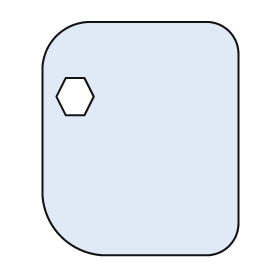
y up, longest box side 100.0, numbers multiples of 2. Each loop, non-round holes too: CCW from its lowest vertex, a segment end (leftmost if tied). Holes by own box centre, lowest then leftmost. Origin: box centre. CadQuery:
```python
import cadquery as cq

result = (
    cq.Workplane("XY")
    .moveTo(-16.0, -50.0)
    .lineTo(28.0, -50.0)
    .threePointArc((38.0, -46.0), (42.0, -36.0))
    .lineTo(42.0, 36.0)
    .threePointArc((38.0, 46.0), (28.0, 50.0))
    .lineTo(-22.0, 50.0)
    .threePointArc((-36.0, 44.0), (-42.0, 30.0))
    .lineTo(-42.0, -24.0)
    .threePointArc((-34.0, -42.0), (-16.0, -50.0))
    .close()
    .moveTo(-32.0, 10.0)
    .lineTo(-24.0, 10.0)
    .lineTo(-20.0, 18.0)
    .lineTo(-24.0, 26.0)
    .lineTo(-32.0, 26.0)
    .lineTo(-36.0, 18.0)
    .close()
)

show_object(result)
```